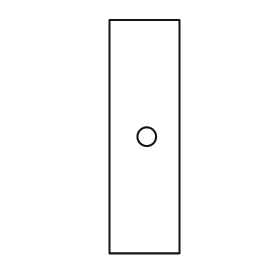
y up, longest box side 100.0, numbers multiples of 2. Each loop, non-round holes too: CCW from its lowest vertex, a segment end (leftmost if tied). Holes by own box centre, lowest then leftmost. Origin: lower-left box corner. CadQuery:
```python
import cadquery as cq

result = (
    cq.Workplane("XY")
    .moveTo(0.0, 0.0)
    .lineTo(30.0, 0.0)
    .lineTo(30.0, 100.0)
    .lineTo(0.0, 100.0)
    .close()
    .moveTo(16.0, 50.0)
    .circle(4.0)
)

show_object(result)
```